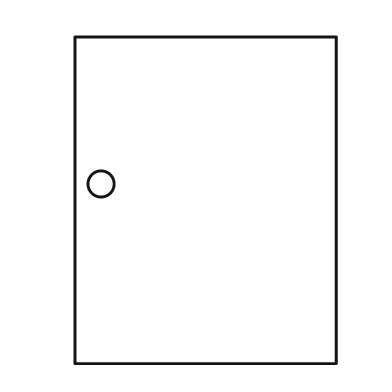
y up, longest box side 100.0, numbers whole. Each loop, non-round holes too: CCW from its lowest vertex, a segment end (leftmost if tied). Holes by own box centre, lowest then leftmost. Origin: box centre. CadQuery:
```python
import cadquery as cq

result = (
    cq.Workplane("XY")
    .moveTo(-40.0, -50.0)
    .lineTo(40.0, -50.0)
    .lineTo(40.0, 50.0)
    .lineTo(-40.0, 50.0)
    .close()
    .moveTo(-32.0, 5.0)
    .circle(4.0)
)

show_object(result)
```